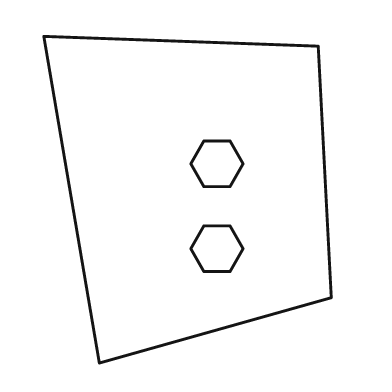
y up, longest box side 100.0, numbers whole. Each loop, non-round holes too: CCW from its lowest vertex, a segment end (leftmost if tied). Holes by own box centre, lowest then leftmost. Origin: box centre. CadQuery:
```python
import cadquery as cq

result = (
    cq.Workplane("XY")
    .moveTo(-27.0, -50.0)
    .lineTo(44.0, -30.0)
    .lineTo(40.0, 47.0)
    .lineTo(-44.0, 50.0)
    .close()
    .moveTo(5.0, -22.0)
    .lineTo(13.0, -22.0)
    .lineTo(17.0, -15.0)
    .lineTo(13.0, -8.0)
    .lineTo(5.0, -8.0)
    .lineTo(1.0, -15.0)
    .close()
    .moveTo(5.0, 4.0)
    .lineTo(13.0, 4.0)
    .lineTo(17.0, 11.0)
    .lineTo(13.0, 18.0)
    .lineTo(5.0, 18.0)
    .lineTo(1.0, 11.0)
    .close()
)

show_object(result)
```